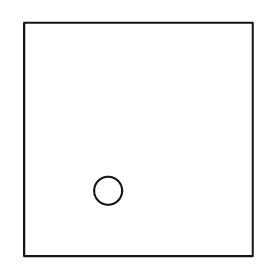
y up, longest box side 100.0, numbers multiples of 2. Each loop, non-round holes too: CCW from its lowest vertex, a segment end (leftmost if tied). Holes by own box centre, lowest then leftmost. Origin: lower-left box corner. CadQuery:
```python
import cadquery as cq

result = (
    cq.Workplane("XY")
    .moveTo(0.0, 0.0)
    .lineTo(98.0, 0.0)
    .lineTo(98.0, 100.0)
    .lineTo(0.0, 100.0)
    .close()
    .moveTo(36.0, 28.0)
    .circle(6.0)
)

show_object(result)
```